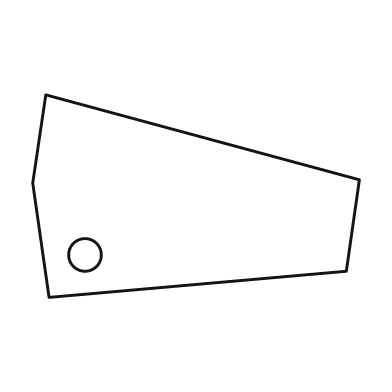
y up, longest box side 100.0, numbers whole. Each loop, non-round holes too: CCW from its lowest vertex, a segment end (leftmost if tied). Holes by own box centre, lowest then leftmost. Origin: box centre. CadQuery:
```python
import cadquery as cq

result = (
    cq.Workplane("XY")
    .moveTo(-45.0, -31.0)
    .lineTo(46.0, -23.0)
    .lineTo(50.0, 5.0)
    .lineTo(-46.0, 31.0)
    .lineTo(-50.0, 4.0)
    .close()
    .moveTo(-34.0, -18.0)
    .circle(5.0)
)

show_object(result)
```